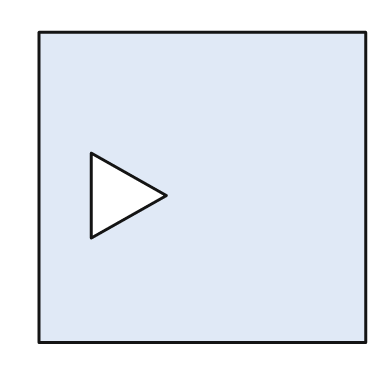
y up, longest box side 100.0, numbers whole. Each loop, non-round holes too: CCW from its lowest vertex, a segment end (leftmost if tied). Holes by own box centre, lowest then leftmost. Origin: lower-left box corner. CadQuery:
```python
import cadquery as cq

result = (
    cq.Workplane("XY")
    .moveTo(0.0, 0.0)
    .lineTo(100.0, 0.0)
    .lineTo(100.0, 95.0)
    .lineTo(0.0, 95.0)
    .close()
    .moveTo(16.0, 32.0)
    .lineTo(39.0, 45.0)
    .lineTo(16.0, 58.0)
    .close()
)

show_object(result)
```